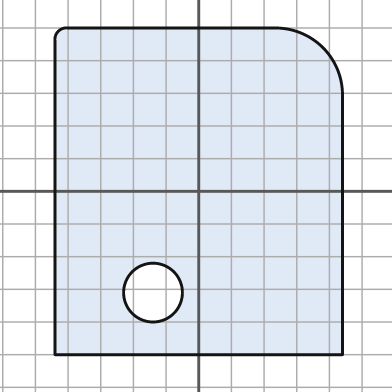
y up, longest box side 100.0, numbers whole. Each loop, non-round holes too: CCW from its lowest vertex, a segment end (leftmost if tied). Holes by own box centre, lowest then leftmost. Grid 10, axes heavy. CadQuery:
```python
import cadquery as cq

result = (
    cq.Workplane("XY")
    .moveTo(-44.0, -50.0)
    .lineTo(44.0, -50.0)
    .lineTo(44.0, 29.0)
    .threePointArc((38.0, 44.0), (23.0, 50.0))
    .lineTo(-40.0, 50.0)
    .threePointArc((-43.0, 49.0), (-44.0, 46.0))
    .close()
    .moveTo(-14.0, -31.0)
    .circle(9.0)
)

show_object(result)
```